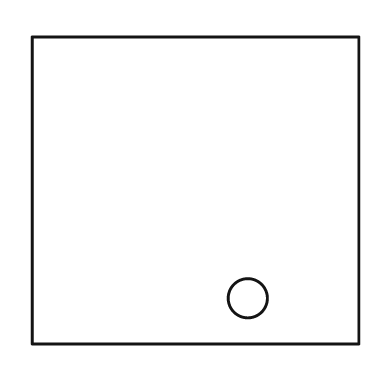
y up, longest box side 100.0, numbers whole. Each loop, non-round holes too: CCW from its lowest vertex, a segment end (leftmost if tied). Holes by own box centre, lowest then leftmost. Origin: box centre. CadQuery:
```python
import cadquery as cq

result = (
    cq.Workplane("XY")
    .moveTo(-50.0, -47.0)
    .lineTo(50.0, -47.0)
    .lineTo(50.0, 47.0)
    .lineTo(-50.0, 47.0)
    .close()
    .moveTo(16.0, -33.0)
    .circle(6.0)
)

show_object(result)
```